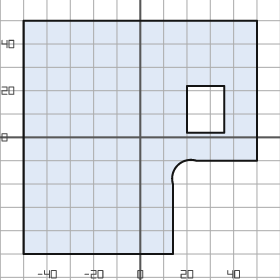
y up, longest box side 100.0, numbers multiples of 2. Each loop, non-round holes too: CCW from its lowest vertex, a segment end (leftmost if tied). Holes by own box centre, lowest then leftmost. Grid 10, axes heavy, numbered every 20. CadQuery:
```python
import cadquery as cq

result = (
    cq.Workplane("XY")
    .moveTo(-50.0, -50.0)
    .lineTo(14.0, -50.0)
    .lineTo(14.0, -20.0)
    .threePointArc((16.0, -12.0), (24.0, -10.0))
    .lineTo(50.0, -10.0)
    .lineTo(50.0, 50.0)
    .lineTo(-50.0, 50.0)
    .close()
    .moveTo(20.0, 2.0)
    .lineTo(36.0, 2.0)
    .lineTo(36.0, 22.0)
    .lineTo(20.0, 22.0)
    .close()
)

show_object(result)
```